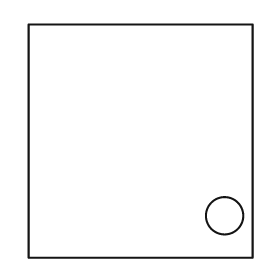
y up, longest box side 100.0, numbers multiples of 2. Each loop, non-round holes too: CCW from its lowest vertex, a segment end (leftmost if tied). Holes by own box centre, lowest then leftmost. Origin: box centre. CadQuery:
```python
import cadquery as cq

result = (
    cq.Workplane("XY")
    .moveTo(-48.0, -50.0)
    .lineTo(48.0, -50.0)
    .lineTo(48.0, 50.0)
    .lineTo(-48.0, 50.0)
    .close()
    .moveTo(36.0, -32.0)
    .circle(8.0)
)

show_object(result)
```